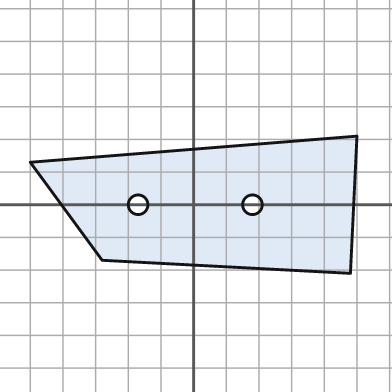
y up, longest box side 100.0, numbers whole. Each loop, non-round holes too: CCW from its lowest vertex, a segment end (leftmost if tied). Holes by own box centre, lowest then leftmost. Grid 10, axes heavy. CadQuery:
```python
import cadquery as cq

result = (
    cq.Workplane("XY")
    .moveTo(48.0, -21.0)
    .lineTo(50.0, 21.0)
    .lineTo(-50.0, 13.0)
    .lineTo(-28.0, -17.0)
    .close()
    .moveTo(-17.0, 0.0)
    .circle(3.0)
    .moveTo(18.0, 0.0)
    .circle(3.0)
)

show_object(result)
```